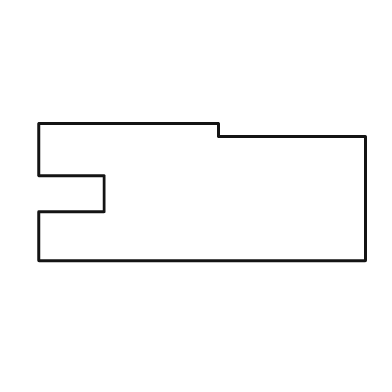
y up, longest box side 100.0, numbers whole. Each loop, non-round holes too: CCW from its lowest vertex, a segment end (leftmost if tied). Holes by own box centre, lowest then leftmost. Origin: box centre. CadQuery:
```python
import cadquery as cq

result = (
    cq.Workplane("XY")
    .moveTo(-50.0, -21.0)
    .lineTo(50.0, -21.0)
    .lineTo(50.0, 17.0)
    .lineTo(5.0, 17.0)
    .lineTo(5.0, 21.0)
    .lineTo(-50.0, 21.0)
    .lineTo(-50.0, 5.0)
    .lineTo(-30.0, 5.0)
    .lineTo(-30.0, -6.0)
    .lineTo(-50.0, -6.0)
    .close()
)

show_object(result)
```